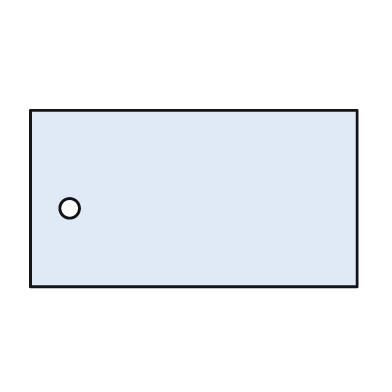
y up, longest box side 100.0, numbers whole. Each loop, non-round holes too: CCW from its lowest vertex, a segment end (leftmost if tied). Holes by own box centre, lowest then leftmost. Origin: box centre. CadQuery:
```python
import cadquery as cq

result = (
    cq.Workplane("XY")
    .moveTo(-50.0, -27.0)
    .lineTo(50.0, -27.0)
    .lineTo(50.0, 27.0)
    .lineTo(-50.0, 27.0)
    .close()
    .moveTo(-38.0, -3.0)
    .circle(3.0)
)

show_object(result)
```